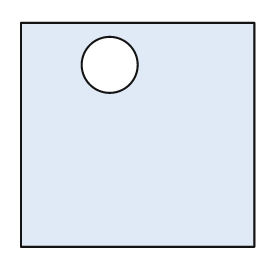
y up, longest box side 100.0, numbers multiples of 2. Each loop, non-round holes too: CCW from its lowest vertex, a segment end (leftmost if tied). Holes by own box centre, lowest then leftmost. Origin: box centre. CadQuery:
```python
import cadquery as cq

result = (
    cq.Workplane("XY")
    .moveTo(-50.0, -48.0)
    .lineTo(50.0, -48.0)
    .lineTo(50.0, 48.0)
    .lineTo(-50.0, 48.0)
    .close()
    .moveTo(-12.0, 30.0)
    .circle(12.0)
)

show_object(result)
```